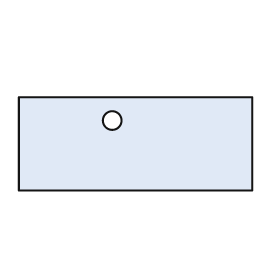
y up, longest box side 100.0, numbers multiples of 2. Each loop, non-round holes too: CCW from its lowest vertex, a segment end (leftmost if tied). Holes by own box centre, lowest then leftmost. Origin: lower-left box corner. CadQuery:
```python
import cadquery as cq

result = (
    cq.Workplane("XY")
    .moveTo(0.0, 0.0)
    .lineTo(100.0, 0.0)
    .lineTo(100.0, 40.0)
    .lineTo(0.0, 40.0)
    .close()
    .moveTo(40.0, 30.0)
    .circle(4.0)
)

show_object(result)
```